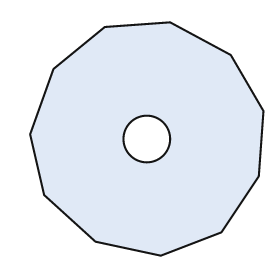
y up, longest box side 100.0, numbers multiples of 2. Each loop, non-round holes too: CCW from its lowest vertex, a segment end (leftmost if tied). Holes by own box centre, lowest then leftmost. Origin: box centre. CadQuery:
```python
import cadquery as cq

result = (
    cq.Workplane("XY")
    .moveTo(6.0, -50.0)
    .lineTo(32.0, -40.0)
    .lineTo(48.0, -16.0)
    .lineTo(50.0, 12.0)
    .lineTo(36.0, 36.0)
    .lineTo(10.0, 50.0)
    .lineTo(-18.0, 48.0)
    .lineTo(-40.0, 30.0)
    .lineTo(-50.0, 2.0)
    .lineTo(-44.0, -24.0)
    .lineTo(-22.0, -44.0)
    .close()
    .moveTo(0.0, 0.0)
    .circle(10.0)
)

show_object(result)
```